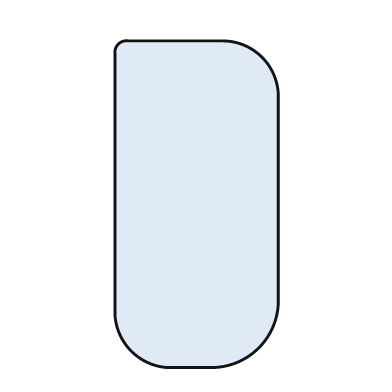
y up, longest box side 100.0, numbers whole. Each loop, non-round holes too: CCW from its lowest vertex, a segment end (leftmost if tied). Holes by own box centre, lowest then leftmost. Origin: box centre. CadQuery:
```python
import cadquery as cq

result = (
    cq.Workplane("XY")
    .moveTo(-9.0, -50.0)
    .lineTo(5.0, -50.0)
    .threePointArc((19.0, -44.0), (25.0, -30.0))
    .lineTo(25.0, 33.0)
    .threePointArc((20.0, 45.0), (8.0, 50.0))
    .lineTo(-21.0, 50.0)
    .threePointArc((-24.0, 49.0), (-25.0, 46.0))
    .lineTo(-25.0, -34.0)
    .threePointArc((-20.0, -45.0), (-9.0, -50.0))
    .close()
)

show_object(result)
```